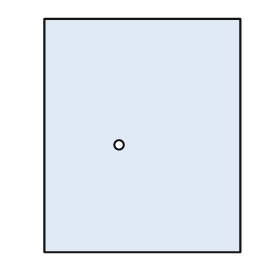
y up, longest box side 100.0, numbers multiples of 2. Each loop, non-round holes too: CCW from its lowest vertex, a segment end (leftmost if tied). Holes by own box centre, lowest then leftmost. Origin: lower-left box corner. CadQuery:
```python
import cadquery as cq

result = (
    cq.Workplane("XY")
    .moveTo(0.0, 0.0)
    .lineTo(84.0, 0.0)
    .lineTo(84.0, 100.0)
    .lineTo(0.0, 100.0)
    .close()
    .moveTo(32.0, 46.0)
    .circle(2.0)
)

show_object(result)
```